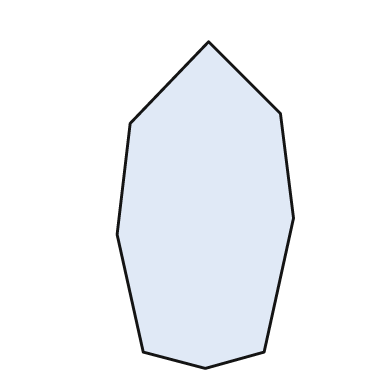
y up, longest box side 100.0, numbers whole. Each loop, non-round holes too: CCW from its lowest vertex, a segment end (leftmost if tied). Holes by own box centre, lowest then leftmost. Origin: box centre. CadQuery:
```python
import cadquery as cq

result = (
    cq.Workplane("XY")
    .moveTo(0.0, -50.0)
    .lineTo(18.0, -45.0)
    .lineTo(27.0, -4.0)
    .lineTo(23.0, 28.0)
    .lineTo(1.0, 50.0)
    .lineTo(-23.0, 25.0)
    .lineTo(-27.0, -9.0)
    .lineTo(-19.0, -45.0)
    .close()
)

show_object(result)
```